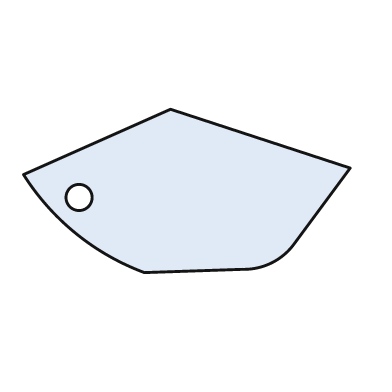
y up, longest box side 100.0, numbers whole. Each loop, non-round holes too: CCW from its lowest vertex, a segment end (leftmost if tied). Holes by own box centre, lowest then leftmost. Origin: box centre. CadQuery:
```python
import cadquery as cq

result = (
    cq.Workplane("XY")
    .moveTo(-13.0, -25.0)
    .lineTo(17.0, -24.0)
    .threePointArc((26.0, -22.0), (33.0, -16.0))
    .lineTo(50.0, 7.0)
    .lineTo(-5.0, 25.0)
    .lineTo(-50.0, 5.0)
    .threePointArc((-34.0, -13.0), (-13.0, -25.0))
    .close()
    .moveTo(-33.0, -2.0)
    .circle(4.0)
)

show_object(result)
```